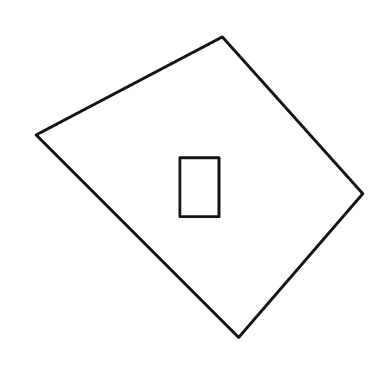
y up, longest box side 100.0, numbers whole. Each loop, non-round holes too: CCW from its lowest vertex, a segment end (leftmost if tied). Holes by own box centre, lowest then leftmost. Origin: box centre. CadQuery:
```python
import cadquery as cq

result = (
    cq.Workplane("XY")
    .moveTo(12.0, -46.0)
    .lineTo(50.0, -2.0)
    .lineTo(7.0, 46.0)
    .lineTo(-50.0, 16.0)
    .close()
    .moveTo(-6.0, -9.0)
    .lineTo(6.0, -9.0)
    .lineTo(6.0, 9.0)
    .lineTo(-6.0, 9.0)
    .close()
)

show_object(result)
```